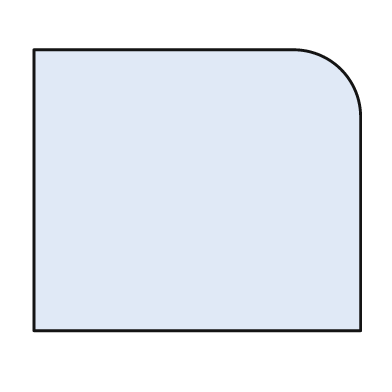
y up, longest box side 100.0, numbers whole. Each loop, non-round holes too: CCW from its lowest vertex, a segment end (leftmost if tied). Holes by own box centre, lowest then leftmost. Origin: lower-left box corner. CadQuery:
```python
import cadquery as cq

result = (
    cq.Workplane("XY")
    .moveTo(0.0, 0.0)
    .lineTo(100.0, 0.0)
    .lineTo(100.0, 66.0)
    .threePointArc((94.0, 80.0), (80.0, 86.0))
    .lineTo(0.0, 86.0)
    .close()
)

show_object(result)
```